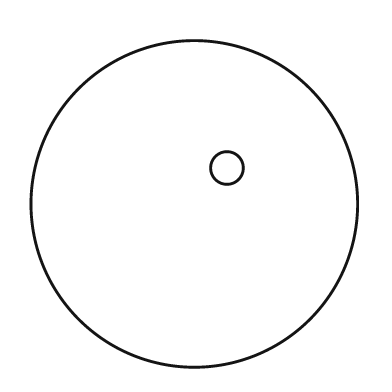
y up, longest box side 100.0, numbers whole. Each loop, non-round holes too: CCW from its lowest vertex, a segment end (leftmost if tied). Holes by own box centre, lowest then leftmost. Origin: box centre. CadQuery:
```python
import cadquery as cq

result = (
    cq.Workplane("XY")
    .moveTo(0.0, 0.0)
    .circle(50.0)
    .moveTo(10.0, 11.0)
    .circle(5.0)
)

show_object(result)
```